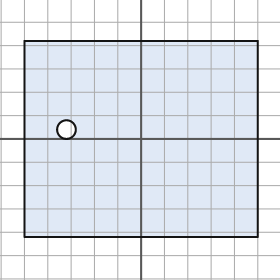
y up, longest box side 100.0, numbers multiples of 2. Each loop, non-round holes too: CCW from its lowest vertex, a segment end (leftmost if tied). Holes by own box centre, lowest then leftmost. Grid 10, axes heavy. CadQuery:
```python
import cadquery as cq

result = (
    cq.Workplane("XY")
    .moveTo(-50.0, -42.0)
    .lineTo(50.0, -42.0)
    .lineTo(50.0, 42.0)
    .lineTo(-50.0, 42.0)
    .close()
    .moveTo(-32.0, 4.0)
    .circle(4.0)
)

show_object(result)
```